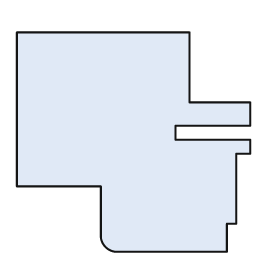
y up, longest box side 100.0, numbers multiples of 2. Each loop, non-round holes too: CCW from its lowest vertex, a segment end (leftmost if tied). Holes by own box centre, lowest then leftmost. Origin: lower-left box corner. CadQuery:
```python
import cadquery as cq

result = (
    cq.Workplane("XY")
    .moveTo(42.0, 0.0)
    .lineTo(90.0, 0.0)
    .lineTo(90.0, 12.0)
    .lineTo(94.0, 12.0)
    .lineTo(94.0, 42.0)
    .lineTo(100.0, 42.0)
    .lineTo(100.0, 48.0)
    .lineTo(68.0, 48.0)
    .lineTo(68.0, 54.0)
    .lineTo(100.0, 54.0)
    .lineTo(100.0, 64.0)
    .lineTo(74.0, 64.0)
    .lineTo(74.0, 94.0)
    .lineTo(0.0, 94.0)
    .lineTo(0.0, 28.0)
    .lineTo(36.0, 28.0)
    .lineTo(36.0, 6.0)
    .threePointArc((38.0, 2.0), (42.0, 0.0))
    .close()
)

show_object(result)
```